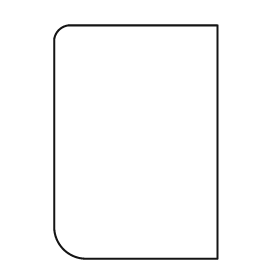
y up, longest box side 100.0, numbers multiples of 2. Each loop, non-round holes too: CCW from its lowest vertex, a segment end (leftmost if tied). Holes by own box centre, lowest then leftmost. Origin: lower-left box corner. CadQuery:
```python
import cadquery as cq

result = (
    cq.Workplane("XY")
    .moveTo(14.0, 0.0)
    .lineTo(70.0, 0.0)
    .lineTo(70.0, 100.0)
    .lineTo(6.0, 100.0)
    .threePointArc((2.0, 98.0), (0.0, 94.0))
    .lineTo(0.0, 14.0)
    .threePointArc((4.0, 4.0), (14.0, 0.0))
    .close()
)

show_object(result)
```